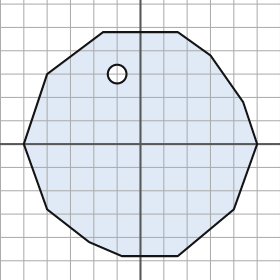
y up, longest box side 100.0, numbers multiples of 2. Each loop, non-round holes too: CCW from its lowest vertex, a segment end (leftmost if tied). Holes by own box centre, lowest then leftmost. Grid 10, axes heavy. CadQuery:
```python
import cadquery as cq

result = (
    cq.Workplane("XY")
    .moveTo(-8.0, -48.0)
    .lineTo(16.0, -48.0)
    .lineTo(40.0, -28.0)
    .lineTo(50.0, 0.0)
    .lineTo(44.0, 18.0)
    .lineTo(30.0, 38.0)
    .lineTo(16.0, 48.0)
    .lineTo(-16.0, 48.0)
    .lineTo(-40.0, 30.0)
    .lineTo(-50.0, 0.0)
    .lineTo(-40.0, -28.0)
    .lineTo(-22.0, -42.0)
    .close()
    .moveTo(-10.0, 30.0)
    .circle(4.0)
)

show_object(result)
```